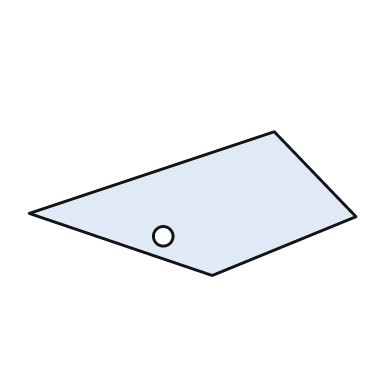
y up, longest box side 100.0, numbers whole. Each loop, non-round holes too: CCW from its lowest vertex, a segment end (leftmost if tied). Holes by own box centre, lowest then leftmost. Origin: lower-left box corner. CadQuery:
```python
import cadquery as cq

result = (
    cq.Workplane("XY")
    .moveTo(56.0, 0.0)
    .lineTo(100.0, 18.0)
    .lineTo(75.0, 44.0)
    .lineTo(0.0, 19.0)
    .close()
    .moveTo(41.0, 12.0)
    .circle(3.0)
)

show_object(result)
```